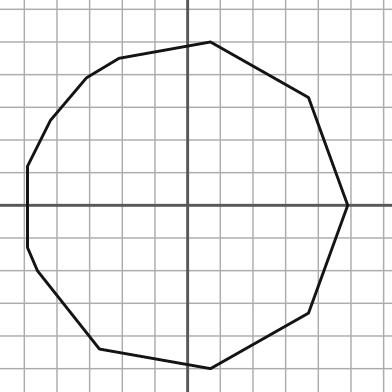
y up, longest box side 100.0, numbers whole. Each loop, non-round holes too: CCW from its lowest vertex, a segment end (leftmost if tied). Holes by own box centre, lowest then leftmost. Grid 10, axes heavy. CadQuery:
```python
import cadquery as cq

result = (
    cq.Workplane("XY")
    .moveTo(7.0, -50.0)
    .lineTo(37.0, -33.0)
    .lineTo(49.0, 0.0)
    .lineTo(37.0, 33.0)
    .lineTo(7.0, 50.0)
    .lineTo(-21.0, 45.0)
    .lineTo(-31.0, 39.0)
    .lineTo(-42.0, 26.0)
    .lineTo(-49.0, 12.0)
    .lineTo(-49.0, -13.0)
    .lineTo(-46.0, -20.0)
    .lineTo(-27.0, -44.0)
    .close()
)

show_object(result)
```